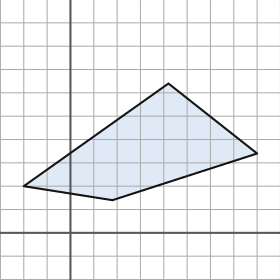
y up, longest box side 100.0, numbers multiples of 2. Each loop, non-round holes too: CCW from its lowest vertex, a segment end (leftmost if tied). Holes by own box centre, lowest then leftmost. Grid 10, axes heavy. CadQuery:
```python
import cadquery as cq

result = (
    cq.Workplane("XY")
    .moveTo(18.0, 14.0)
    .lineTo(80.0, 34.0)
    .lineTo(42.0, 64.0)
    .lineTo(-20.0, 20.0)
    .close()
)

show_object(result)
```